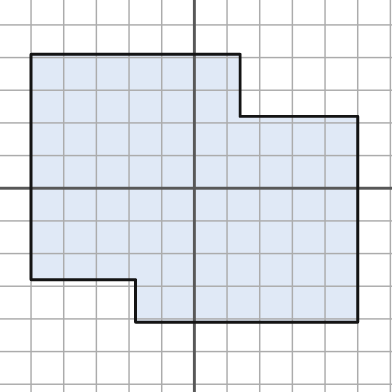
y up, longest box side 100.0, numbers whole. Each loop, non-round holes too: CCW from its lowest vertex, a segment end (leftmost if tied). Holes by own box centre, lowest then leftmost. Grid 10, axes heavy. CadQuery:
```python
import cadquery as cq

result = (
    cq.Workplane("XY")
    .moveTo(-18.0, -41.0)
    .lineTo(50.0, -41.0)
    .lineTo(50.0, 22.0)
    .lineTo(14.0, 22.0)
    .lineTo(14.0, 41.0)
    .lineTo(-50.0, 41.0)
    .lineTo(-50.0, -28.0)
    .lineTo(-18.0, -28.0)
    .close()
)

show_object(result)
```